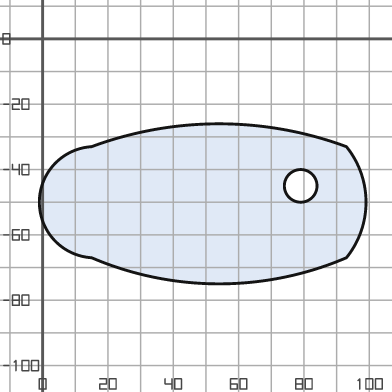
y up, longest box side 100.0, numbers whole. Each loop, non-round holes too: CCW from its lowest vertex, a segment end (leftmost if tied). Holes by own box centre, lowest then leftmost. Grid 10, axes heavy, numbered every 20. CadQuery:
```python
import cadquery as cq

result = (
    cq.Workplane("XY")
    .moveTo(15.0, -67.0)
    .threePointArc((54.0, -75.0), (93.0, -67.0))
    .threePointArc((99.0, -50.0), (93.0, -33.0))
    .threePointArc((54.0, -26.0), (15.0, -33.0))
    .threePointArc((-1.0, -50.0), (15.0, -67.0))
    .close()
    .moveTo(79.0, -45.0)
    .circle(5.0)
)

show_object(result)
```